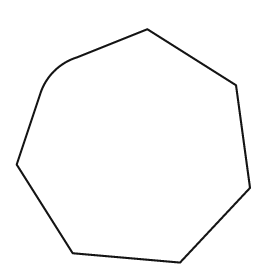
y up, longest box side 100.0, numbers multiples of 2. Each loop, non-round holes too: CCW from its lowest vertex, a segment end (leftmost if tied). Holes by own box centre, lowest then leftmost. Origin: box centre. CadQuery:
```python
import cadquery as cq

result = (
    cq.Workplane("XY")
    .moveTo(20.0, -50.0)
    .lineTo(50.0, -18.0)
    .lineTo(44.0, 26.0)
    .lineTo(6.0, 50.0)
    .lineTo(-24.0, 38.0)
    .threePointArc((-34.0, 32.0), (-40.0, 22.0))
    .lineTo(-50.0, -8.0)
    .lineTo(-26.0, -46.0)
    .close()
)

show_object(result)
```